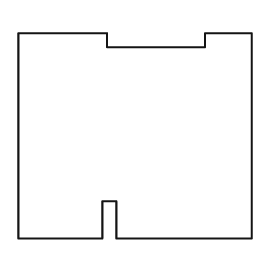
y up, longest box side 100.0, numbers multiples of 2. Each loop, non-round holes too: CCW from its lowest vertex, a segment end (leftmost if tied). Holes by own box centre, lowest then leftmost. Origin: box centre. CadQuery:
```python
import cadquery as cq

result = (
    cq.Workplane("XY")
    .moveTo(-50.0, -44.0)
    .lineTo(-14.0, -44.0)
    .lineTo(-14.0, -28.0)
    .lineTo(-8.0, -28.0)
    .lineTo(-8.0, -44.0)
    .lineTo(50.0, -44.0)
    .lineTo(50.0, 44.0)
    .lineTo(30.0, 44.0)
    .lineTo(30.0, 38.0)
    .lineTo(-12.0, 38.0)
    .lineTo(-12.0, 44.0)
    .lineTo(-50.0, 44.0)
    .close()
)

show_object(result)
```